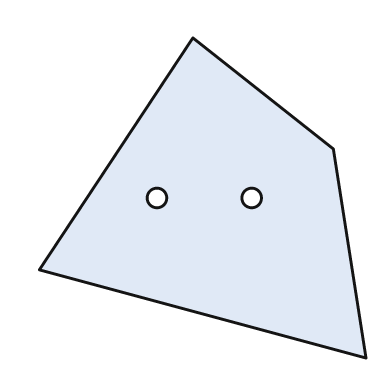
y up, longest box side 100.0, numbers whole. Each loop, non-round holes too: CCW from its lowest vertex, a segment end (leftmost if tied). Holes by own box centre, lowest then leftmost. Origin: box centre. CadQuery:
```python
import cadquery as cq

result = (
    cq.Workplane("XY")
    .moveTo(50.0, -49.0)
    .lineTo(40.0, 15.0)
    .lineTo(-3.0, 49.0)
    .lineTo(-50.0, -22.0)
    .close()
    .moveTo(-14.0, 0.0)
    .circle(3.0)
    .moveTo(15.0, 0.0)
    .circle(3.0)
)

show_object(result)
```